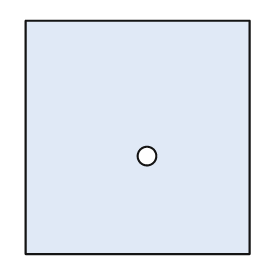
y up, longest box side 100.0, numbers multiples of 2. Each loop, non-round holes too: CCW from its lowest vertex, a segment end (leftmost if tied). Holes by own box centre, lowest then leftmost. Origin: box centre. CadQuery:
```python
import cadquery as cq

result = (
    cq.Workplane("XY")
    .moveTo(-48.0, -50.0)
    .lineTo(48.0, -50.0)
    .lineTo(48.0, 50.0)
    .lineTo(-48.0, 50.0)
    .close()
    .moveTo(4.0, -8.0)
    .circle(4.0)
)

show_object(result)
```